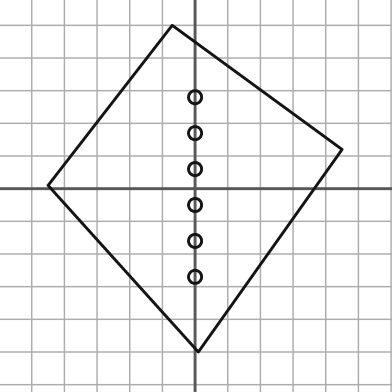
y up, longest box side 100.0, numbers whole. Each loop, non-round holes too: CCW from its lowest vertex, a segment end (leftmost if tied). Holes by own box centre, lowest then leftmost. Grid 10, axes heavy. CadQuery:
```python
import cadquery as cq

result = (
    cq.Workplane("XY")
    .moveTo(1.0, -50.0)
    .lineTo(45.0, 12.0)
    .lineTo(-7.0, 50.0)
    .lineTo(-45.0, 1.0)
    .close()
    .moveTo(0.0, -27.0)
    .circle(2.0)
    .moveTo(0.0, -16.0)
    .circle(2.0)
    .moveTo(0.0, -5.0)
    .circle(2.0)
    .moveTo(0.0, 6.0)
    .circle(2.0)
    .moveTo(0.0, 17.0)
    .circle(2.0)
    .moveTo(0.0, 28.0)
    .circle(2.0)
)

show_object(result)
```